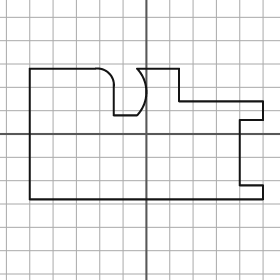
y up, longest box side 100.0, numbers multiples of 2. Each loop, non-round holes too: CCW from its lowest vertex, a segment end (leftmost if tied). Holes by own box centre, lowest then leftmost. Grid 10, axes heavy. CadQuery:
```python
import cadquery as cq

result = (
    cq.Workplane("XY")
    .moveTo(-50.0, -28.0)
    .lineTo(50.0, -28.0)
    .lineTo(50.0, -22.0)
    .lineTo(40.0, -22.0)
    .lineTo(40.0, 6.0)
    .lineTo(50.0, 6.0)
    .lineTo(50.0, 14.0)
    .lineTo(14.0, 14.0)
    .lineTo(14.0, 28.0)
    .lineTo(-4.0, 28.0)
    .threePointArc((0.0, 18.0), (-4.0, 8.0))
    .lineTo(-14.0, 8.0)
    .lineTo(-14.0, 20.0)
    .threePointArc((-16.0, 26.0), (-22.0, 28.0))
    .lineTo(-50.0, 28.0)
    .close()
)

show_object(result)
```